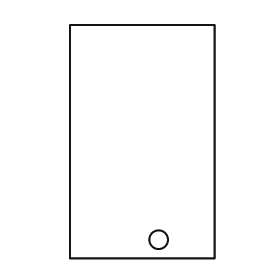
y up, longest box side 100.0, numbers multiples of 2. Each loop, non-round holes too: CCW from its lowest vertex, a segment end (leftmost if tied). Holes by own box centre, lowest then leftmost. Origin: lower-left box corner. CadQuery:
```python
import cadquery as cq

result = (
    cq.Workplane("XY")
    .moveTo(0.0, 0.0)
    .lineTo(62.0, 0.0)
    .lineTo(62.0, 100.0)
    .lineTo(0.0, 100.0)
    .close()
    .moveTo(38.0, 8.0)
    .circle(4.0)
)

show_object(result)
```